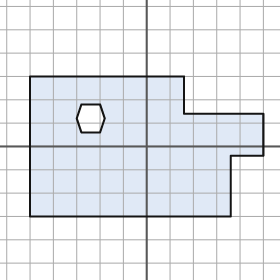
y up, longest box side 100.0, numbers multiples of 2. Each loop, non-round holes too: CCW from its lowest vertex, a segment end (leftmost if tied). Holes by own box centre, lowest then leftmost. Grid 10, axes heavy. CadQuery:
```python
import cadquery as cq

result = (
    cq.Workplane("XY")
    .moveTo(-50.0, -30.0)
    .lineTo(36.0, -30.0)
    .lineTo(36.0, -4.0)
    .lineTo(50.0, -4.0)
    .lineTo(50.0, 14.0)
    .lineTo(16.0, 14.0)
    .lineTo(16.0, 30.0)
    .lineTo(-50.0, 30.0)
    .close()
    .moveTo(-28.0, 6.0)
    .lineTo(-20.0, 6.0)
    .lineTo(-18.0, 12.0)
    .lineTo(-20.0, 18.0)
    .lineTo(-28.0, 18.0)
    .lineTo(-30.0, 12.0)
    .close()
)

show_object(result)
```